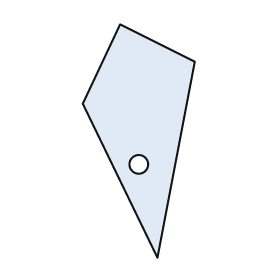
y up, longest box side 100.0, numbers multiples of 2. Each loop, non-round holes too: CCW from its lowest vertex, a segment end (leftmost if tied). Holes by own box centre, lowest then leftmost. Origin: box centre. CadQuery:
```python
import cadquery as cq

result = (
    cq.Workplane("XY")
    .moveTo(8.0, -50.0)
    .lineTo(24.0, 34.0)
    .lineTo(-8.0, 50.0)
    .lineTo(-24.0, 16.0)
    .close()
    .moveTo(0.0, -10.0)
    .circle(4.0)
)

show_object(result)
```